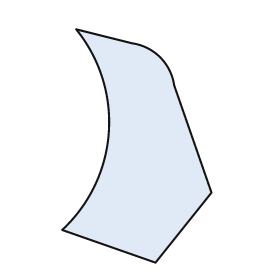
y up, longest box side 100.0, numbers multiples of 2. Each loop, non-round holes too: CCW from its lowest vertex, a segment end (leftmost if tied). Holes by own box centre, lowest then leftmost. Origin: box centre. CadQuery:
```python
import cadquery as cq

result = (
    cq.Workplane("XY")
    .moveTo(8.0, -50.0)
    .lineTo(32.0, -20.0)
    .lineTo(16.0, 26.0)
    .threePointArc((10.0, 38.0), (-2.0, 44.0))
    .lineTo(-26.0, 50.0)
    .threePointArc((-12.0, 6.0), (-32.0, -36.0))
    .close()
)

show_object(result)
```